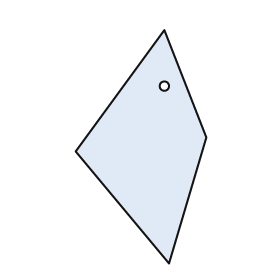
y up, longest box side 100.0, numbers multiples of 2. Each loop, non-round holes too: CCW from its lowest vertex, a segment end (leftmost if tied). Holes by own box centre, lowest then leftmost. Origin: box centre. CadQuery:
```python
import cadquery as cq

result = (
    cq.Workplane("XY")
    .moveTo(12.0, -50.0)
    .lineTo(28.0, 4.0)
    .lineTo(10.0, 50.0)
    .lineTo(-28.0, -2.0)
    .close()
    .moveTo(10.0, 26.0)
    .circle(2.0)
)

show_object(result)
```